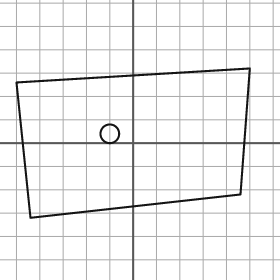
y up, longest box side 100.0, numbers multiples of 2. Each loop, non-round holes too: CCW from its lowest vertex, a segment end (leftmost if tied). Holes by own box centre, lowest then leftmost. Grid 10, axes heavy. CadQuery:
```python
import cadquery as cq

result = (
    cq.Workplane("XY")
    .moveTo(-44.0, -32.0)
    .lineTo(46.0, -22.0)
    .lineTo(50.0, 32.0)
    .lineTo(-50.0, 26.0)
    .close()
    .moveTo(-10.0, 4.0)
    .circle(4.0)
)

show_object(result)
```